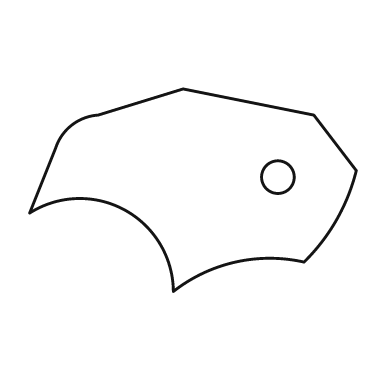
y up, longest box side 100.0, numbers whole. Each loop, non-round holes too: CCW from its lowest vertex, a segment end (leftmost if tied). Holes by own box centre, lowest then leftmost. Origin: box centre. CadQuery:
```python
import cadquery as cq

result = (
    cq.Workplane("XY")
    .moveTo(-6.0, -31.0)
    .threePointArc((13.0, -22.0), (34.0, -22.0))
    .threePointArc((44.0, -9.0), (50.0, 6.0))
    .lineTo(37.0, 23.0)
    .lineTo(-3.0, 31.0)
    .lineTo(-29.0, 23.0)
    .threePointArc((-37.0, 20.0), (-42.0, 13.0))
    .lineTo(-50.0, -7.0)
    .threePointArc((-21.0, -6.0), (-6.0, -31.0))
    .close()
    .moveTo(26.0, 4.0)
    .circle(5.0)
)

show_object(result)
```